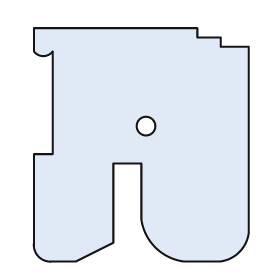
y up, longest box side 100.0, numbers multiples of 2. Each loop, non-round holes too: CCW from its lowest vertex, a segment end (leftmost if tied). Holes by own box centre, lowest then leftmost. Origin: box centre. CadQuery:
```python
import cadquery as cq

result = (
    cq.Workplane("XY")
    .moveTo(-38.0, -50.0)
    .lineTo(-28.0, -50.0)
    .lineTo(-12.0, -42.0)
    .lineTo(-12.0, -8.0)
    .lineTo(0.0, -8.0)
    .lineTo(0.0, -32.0)
    .threePointArc((6.0, -44.0), (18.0, -50.0))
    .lineTo(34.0, -50.0)
    .threePointArc((42.0, -46.0), (46.0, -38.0))
    .lineTo(46.0, 42.0)
    .lineTo(34.0, 42.0)
    .lineTo(34.0, 46.0)
    .lineTo(24.0, 46.0)
    .lineTo(24.0, 50.0)
    .lineTo(-46.0, 50.0)
    .lineTo(-46.0, 40.0)
    .threePointArc((-42.0, 38.0), (-38.0, 40.0))
    .lineTo(-38.0, -4.0)
    .lineTo(-46.0, -4.0)
    .lineTo(-46.0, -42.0)
    .threePointArc((-44.0, -48.0), (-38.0, -50.0))
    .close()
    .moveTo(2.0, 8.0)
    .circle(4.0)
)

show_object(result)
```